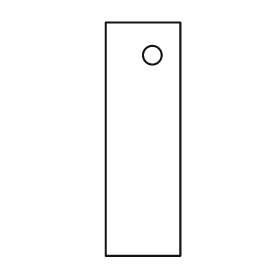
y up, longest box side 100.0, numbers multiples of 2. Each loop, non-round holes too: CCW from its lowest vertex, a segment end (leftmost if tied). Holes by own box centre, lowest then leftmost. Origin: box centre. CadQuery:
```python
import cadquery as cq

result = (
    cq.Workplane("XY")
    .moveTo(-16.0, -50.0)
    .lineTo(16.0, -50.0)
    .lineTo(16.0, 50.0)
    .lineTo(-16.0, 50.0)
    .close()
    .moveTo(4.0, 36.0)
    .circle(4.0)
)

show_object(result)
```